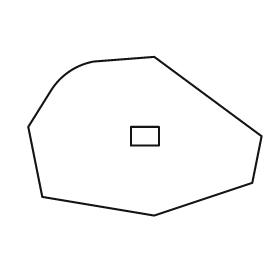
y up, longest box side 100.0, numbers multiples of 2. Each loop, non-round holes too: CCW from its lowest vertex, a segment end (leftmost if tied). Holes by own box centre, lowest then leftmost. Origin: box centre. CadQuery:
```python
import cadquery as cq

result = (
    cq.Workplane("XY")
    .moveTo(4.0, -34.0)
    .lineTo(46.0, -20.0)
    .lineTo(50.0, 0.0)
    .lineTo(4.0, 34.0)
    .lineTo(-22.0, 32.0)
    .threePointArc((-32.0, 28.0), (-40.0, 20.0))
    .lineTo(-50.0, 4.0)
    .lineTo(-44.0, -26.0)
    .close()
    .moveTo(-6.0, -4.0)
    .lineTo(6.0, -4.0)
    .lineTo(6.0, 4.0)
    .lineTo(-6.0, 4.0)
    .close()
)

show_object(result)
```